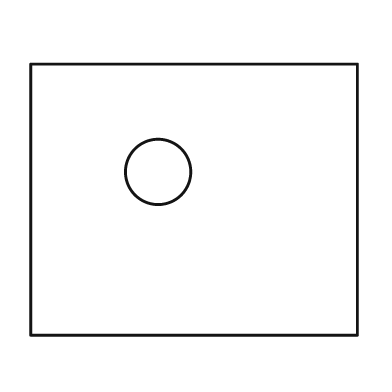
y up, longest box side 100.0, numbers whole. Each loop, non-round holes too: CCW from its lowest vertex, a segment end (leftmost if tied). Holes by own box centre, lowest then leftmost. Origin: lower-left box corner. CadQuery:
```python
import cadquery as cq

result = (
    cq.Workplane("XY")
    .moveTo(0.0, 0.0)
    .lineTo(100.0, 0.0)
    .lineTo(100.0, 83.0)
    .lineTo(0.0, 83.0)
    .close()
    .moveTo(39.0, 50.0)
    .circle(10.0)
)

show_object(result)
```